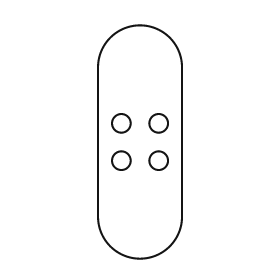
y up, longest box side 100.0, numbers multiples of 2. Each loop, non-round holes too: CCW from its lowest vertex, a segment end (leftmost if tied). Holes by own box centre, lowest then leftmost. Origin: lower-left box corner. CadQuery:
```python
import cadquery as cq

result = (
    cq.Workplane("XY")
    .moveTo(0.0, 18.0)
    .threePointArc((18.0, 0.0), (36.0, 18.0))
    .lineTo(36.0, 82.0)
    .threePointArc((18.0, 100.0), (0.0, 82.0))
    .close()
    .moveTo(10.0, 42.0)
    .circle(4.0)
    .moveTo(26.0, 42.0)
    .circle(4.0)
    .moveTo(10.0, 58.0)
    .circle(4.0)
    .moveTo(26.0, 58.0)
    .circle(4.0)
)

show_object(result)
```